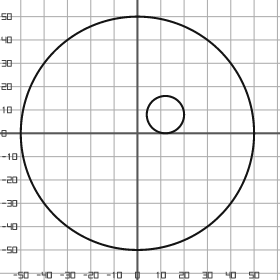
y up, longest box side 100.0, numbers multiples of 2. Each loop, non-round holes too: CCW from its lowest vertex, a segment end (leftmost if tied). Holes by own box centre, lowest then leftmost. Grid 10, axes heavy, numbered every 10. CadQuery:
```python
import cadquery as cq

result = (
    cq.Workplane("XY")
    .moveTo(0.0, 0.0)
    .circle(50.0)
    .moveTo(12.0, 8.0)
    .circle(8.0)
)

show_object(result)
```